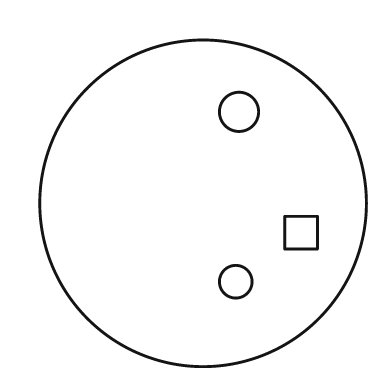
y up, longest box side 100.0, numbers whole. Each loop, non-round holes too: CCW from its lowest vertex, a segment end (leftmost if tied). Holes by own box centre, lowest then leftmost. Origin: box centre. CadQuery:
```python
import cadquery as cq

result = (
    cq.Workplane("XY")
    .moveTo(0.0, 0.0)
    .circle(50.0)
    .moveTo(10.0, -24.0)
    .circle(5.0)
    .moveTo(25.0, -14.0)
    .lineTo(35.0, -14.0)
    .lineTo(35.0, -4.0)
    .lineTo(25.0, -4.0)
    .close()
    .moveTo(11.0, 28.0)
    .circle(6.0)
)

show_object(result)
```